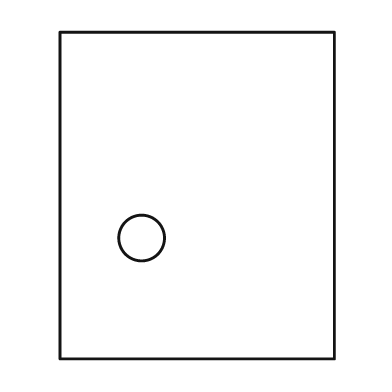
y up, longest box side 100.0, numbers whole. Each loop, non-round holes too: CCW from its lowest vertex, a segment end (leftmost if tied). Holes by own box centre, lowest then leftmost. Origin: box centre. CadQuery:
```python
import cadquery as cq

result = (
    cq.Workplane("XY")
    .moveTo(-42.0, -50.0)
    .lineTo(42.0, -50.0)
    .lineTo(42.0, 50.0)
    .lineTo(-42.0, 50.0)
    .close()
    .moveTo(-17.0, -13.0)
    .circle(7.0)
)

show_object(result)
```